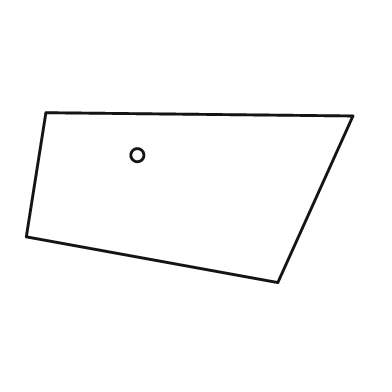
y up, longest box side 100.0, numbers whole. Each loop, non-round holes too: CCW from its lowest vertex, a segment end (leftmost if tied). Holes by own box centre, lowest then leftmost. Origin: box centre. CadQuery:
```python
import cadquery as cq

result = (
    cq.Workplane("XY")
    .moveTo(27.0, -26.0)
    .lineTo(50.0, 25.0)
    .lineTo(-44.0, 26.0)
    .lineTo(-50.0, -12.0)
    .close()
    .moveTo(-16.0, 13.0)
    .circle(2.0)
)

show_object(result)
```